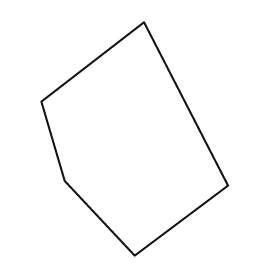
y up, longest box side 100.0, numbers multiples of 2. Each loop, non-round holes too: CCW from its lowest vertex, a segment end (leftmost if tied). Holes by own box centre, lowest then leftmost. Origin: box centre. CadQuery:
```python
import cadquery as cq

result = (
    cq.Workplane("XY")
    .moveTo(0.0, -50.0)
    .lineTo(40.0, -20.0)
    .lineTo(4.0, 50.0)
    .lineTo(-40.0, 16.0)
    .lineTo(-30.0, -18.0)
    .close()
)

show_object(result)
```